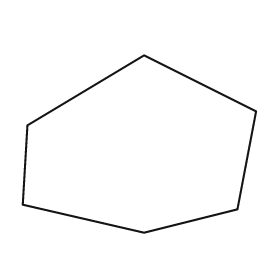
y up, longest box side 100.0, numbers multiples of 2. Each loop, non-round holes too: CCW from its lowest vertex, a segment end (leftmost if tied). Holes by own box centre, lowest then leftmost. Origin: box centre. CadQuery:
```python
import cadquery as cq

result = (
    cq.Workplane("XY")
    .moveTo(2.0, -38.0)
    .lineTo(42.0, -28.0)
    .lineTo(50.0, 14.0)
    .lineTo(2.0, 38.0)
    .lineTo(-48.0, 8.0)
    .lineTo(-50.0, -26.0)
    .close()
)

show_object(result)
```